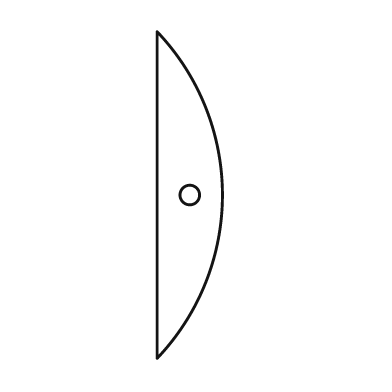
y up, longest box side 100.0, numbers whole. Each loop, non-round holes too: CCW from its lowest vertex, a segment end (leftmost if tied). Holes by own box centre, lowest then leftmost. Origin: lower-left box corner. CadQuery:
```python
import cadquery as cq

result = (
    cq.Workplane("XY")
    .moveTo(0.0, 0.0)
    .threePointArc((20.0, 50.0), (0.0, 100.0))
    .close()
    .moveTo(10.0, 50.0)
    .circle(3.0)
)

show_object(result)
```